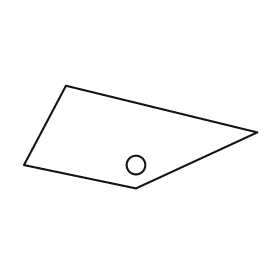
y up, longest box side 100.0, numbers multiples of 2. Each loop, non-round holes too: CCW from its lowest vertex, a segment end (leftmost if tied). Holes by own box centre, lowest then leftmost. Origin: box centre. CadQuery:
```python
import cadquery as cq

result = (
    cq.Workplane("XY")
    .moveTo(-2.0, -22.0)
    .lineTo(50.0, 2.0)
    .lineTo(-32.0, 22.0)
    .lineTo(-50.0, -12.0)
    .close()
    .moveTo(-2.0, -12.0)
    .circle(4.0)
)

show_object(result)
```